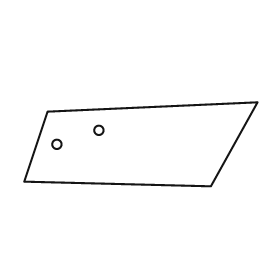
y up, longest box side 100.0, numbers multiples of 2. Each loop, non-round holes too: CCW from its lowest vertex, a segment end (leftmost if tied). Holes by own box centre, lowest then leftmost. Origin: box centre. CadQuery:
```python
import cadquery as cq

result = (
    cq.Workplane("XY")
    .moveTo(30.0, -18.0)
    .lineTo(50.0, 18.0)
    .lineTo(-40.0, 14.0)
    .lineTo(-50.0, -16.0)
    .close()
    .moveTo(-36.0, 0.0)
    .circle(2.0)
    .moveTo(-18.0, 6.0)
    .circle(2.0)
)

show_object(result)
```